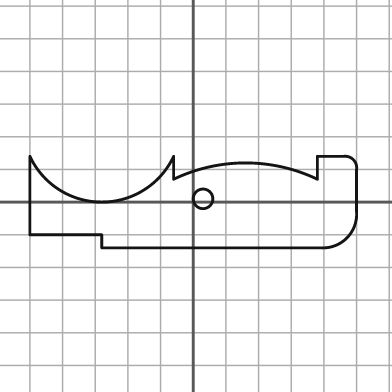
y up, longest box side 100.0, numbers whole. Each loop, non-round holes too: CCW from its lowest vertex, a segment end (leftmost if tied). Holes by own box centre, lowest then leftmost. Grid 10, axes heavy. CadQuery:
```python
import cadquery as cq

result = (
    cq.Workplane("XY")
    .moveTo(-28.0, -14.0)
    .lineTo(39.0, -14.0)
    .threePointArc((47.0, -11.0), (50.0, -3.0))
    .lineTo(50.0, 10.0)
    .threePointArc((49.0, 13.0), (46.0, 14.0))
    .lineTo(38.0, 14.0)
    .lineTo(38.0, 7.0)
    .threePointArc((16.0, 12.0), (-6.0, 7.0))
    .lineTo(-6.0, 14.0)
    .threePointArc((-28.0, 0.0), (-50.0, 14.0))
    .lineTo(-50.0, -10.0)
    .lineTo(-28.0, -10.0)
    .close()
    .moveTo(3.0, 1.0)
    .circle(3.0)
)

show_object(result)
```